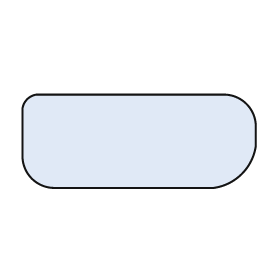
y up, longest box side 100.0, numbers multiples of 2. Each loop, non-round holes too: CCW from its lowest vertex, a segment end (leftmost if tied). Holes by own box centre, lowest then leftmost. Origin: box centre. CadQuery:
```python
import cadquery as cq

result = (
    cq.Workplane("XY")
    .moveTo(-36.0, -20.0)
    .lineTo(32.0, -20.0)
    .threePointArc((44.0, -14.0), (50.0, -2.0))
    .lineTo(50.0, 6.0)
    .threePointArc((46.0, 16.0), (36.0, 20.0))
    .lineTo(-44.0, 20.0)
    .threePointArc((-48.0, 18.0), (-50.0, 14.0))
    .lineTo(-50.0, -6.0)
    .threePointArc((-46.0, -16.0), (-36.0, -20.0))
    .close()
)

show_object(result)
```